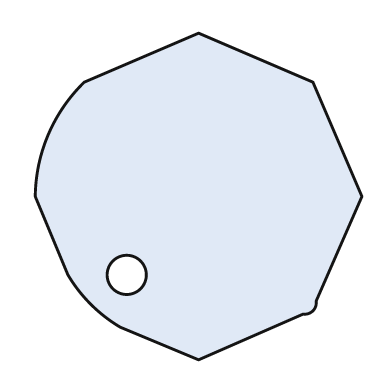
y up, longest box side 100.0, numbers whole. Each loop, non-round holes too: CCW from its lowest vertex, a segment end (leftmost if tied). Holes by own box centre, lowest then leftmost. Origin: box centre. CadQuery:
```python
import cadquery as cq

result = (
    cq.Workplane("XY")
    .moveTo(0.0, -50.0)
    .lineTo(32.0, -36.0)
    .threePointArc((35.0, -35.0), (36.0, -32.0))
    .lineTo(50.0, 0.0)
    .lineTo(35.0, 35.0)
    .lineTo(0.0, 50.0)
    .lineTo(-35.0, 35.0)
    .threePointArc((-46.0, 19.0), (-50.0, 0.0))
    .lineTo(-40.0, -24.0)
    .threePointArc((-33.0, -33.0), (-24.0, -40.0))
    .close()
    .moveTo(-22.0, -24.0)
    .circle(6.0)
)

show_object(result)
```